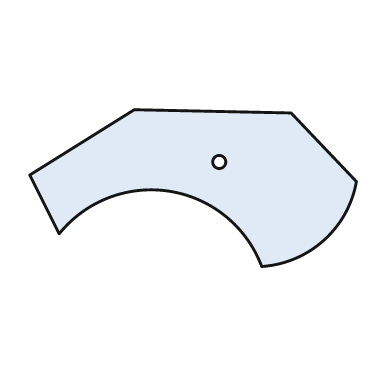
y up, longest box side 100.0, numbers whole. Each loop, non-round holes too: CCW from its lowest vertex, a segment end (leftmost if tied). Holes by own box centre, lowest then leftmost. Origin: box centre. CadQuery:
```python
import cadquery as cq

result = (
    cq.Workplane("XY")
    .moveTo(21.0, -24.0)
    .threePointArc((40.0, -16.0), (50.0, 2.0))
    .lineTo(30.0, 23.0)
    .lineTo(-18.0, 24.0)
    .lineTo(-50.0, 4.0)
    .lineTo(-41.0, -14.0)
    .threePointArc((-7.0, -1.0), (21.0, -24.0))
    .close()
    .moveTo(8.0, 8.0)
    .circle(2.0)
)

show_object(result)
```